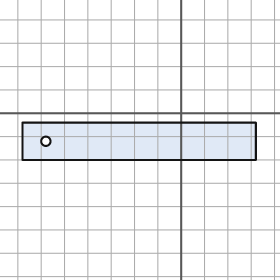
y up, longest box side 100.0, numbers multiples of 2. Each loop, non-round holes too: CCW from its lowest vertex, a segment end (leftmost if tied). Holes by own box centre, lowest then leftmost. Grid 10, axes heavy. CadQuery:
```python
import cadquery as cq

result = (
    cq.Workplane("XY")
    .moveTo(-68.0, -20.0)
    .lineTo(32.0, -20.0)
    .lineTo(32.0, -4.0)
    .lineTo(-68.0, -4.0)
    .close()
    .moveTo(-58.0, -12.0)
    .circle(2.0)
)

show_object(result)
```